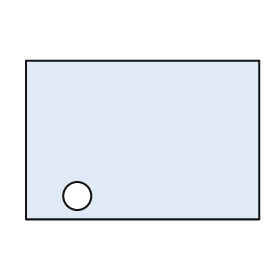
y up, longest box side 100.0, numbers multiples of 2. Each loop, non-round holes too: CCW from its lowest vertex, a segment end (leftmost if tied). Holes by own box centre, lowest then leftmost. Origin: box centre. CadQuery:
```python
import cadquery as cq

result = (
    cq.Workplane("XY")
    .moveTo(-50.0, -34.0)
    .lineTo(50.0, -34.0)
    .lineTo(50.0, 34.0)
    .lineTo(-50.0, 34.0)
    .close()
    .moveTo(-28.0, -24.0)
    .circle(6.0)
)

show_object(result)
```